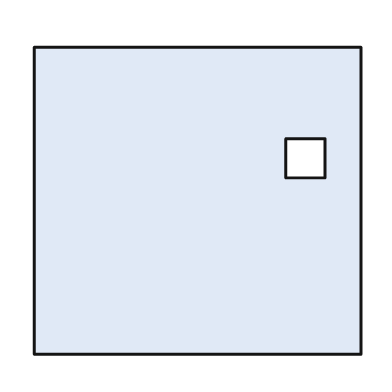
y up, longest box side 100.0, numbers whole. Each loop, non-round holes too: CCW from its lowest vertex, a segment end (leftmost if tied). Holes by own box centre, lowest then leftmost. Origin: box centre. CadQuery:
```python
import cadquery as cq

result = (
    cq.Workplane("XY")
    .moveTo(-50.0, -47.0)
    .lineTo(50.0, -47.0)
    .lineTo(50.0, 47.0)
    .lineTo(-50.0, 47.0)
    .close()
    .moveTo(27.0, 7.0)
    .lineTo(39.0, 7.0)
    .lineTo(39.0, 19.0)
    .lineTo(27.0, 19.0)
    .close()
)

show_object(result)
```